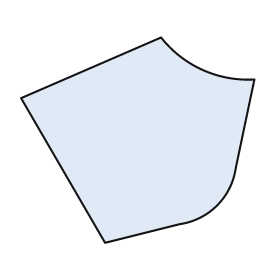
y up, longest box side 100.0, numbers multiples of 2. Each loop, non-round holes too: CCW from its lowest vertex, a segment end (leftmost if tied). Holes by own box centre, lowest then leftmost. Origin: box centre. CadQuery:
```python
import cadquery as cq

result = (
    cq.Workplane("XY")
    .moveTo(-14.0, -44.0)
    .lineTo(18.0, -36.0)
    .threePointArc((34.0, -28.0), (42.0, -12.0))
    .lineTo(50.0, 26.0)
    .threePointArc((28.0, 30.0), (10.0, 44.0))
    .lineTo(-50.0, 18.0)
    .close()
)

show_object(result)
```